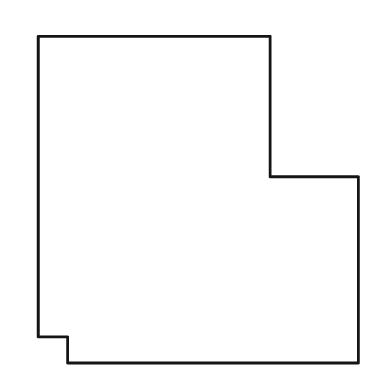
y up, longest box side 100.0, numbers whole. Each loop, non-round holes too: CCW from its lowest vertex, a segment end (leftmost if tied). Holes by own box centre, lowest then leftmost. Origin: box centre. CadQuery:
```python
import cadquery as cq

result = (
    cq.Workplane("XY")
    .moveTo(-40.0, -50.0)
    .lineTo(49.0, -50.0)
    .lineTo(49.0, 7.0)
    .lineTo(22.0, 7.0)
    .lineTo(22.0, 50.0)
    .lineTo(-49.0, 50.0)
    .lineTo(-49.0, -42.0)
    .lineTo(-40.0, -42.0)
    .close()
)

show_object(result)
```